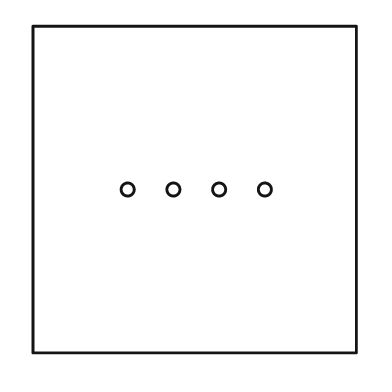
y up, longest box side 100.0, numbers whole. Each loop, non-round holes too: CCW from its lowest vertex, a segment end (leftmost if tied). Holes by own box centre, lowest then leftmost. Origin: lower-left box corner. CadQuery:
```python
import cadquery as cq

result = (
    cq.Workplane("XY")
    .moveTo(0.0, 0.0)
    .lineTo(99.0, 0.0)
    .lineTo(99.0, 100.0)
    .lineTo(0.0, 100.0)
    .close()
    .moveTo(29.0, 50.0)
    .circle(2.0)
    .moveTo(43.0, 50.0)
    .circle(2.0)
    .moveTo(57.0, 50.0)
    .circle(2.0)
    .moveTo(71.0, 50.0)
    .circle(2.0)
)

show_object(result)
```